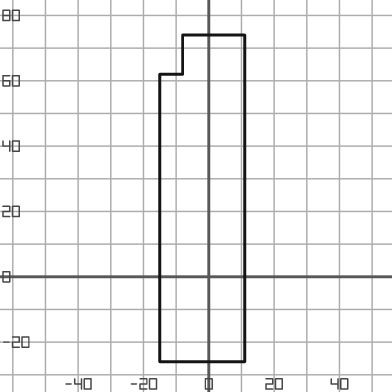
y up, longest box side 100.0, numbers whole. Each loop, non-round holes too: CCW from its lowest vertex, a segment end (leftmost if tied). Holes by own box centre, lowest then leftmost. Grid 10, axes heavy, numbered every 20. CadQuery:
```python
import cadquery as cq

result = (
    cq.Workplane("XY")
    .moveTo(-15.0, -26.0)
    .lineTo(11.0, -26.0)
    .lineTo(11.0, 74.0)
    .lineTo(-8.0, 74.0)
    .lineTo(-8.0, 62.0)
    .lineTo(-15.0, 62.0)
    .close()
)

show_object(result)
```